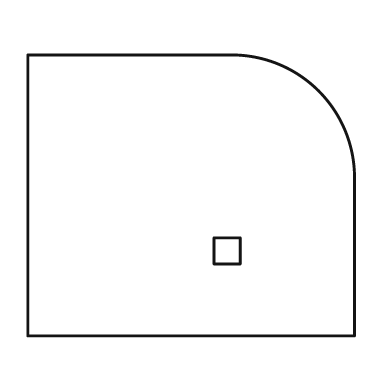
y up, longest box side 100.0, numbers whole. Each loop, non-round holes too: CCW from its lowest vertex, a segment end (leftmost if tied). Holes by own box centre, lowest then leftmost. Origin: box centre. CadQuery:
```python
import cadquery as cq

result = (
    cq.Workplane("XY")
    .moveTo(-50.0, -43.0)
    .lineTo(50.0, -43.0)
    .lineTo(50.0, 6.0)
    .threePointArc((39.0, 32.0), (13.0, 43.0))
    .lineTo(-50.0, 43.0)
    .close()
    .moveTo(7.0, -21.0)
    .lineTo(15.0, -21.0)
    .lineTo(15.0, -13.0)
    .lineTo(7.0, -13.0)
    .close()
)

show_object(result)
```